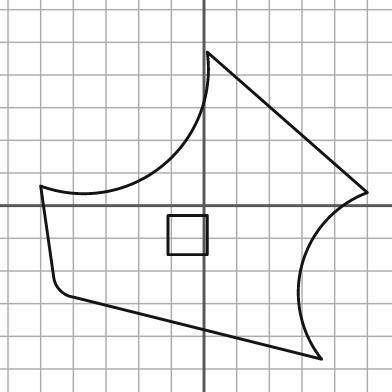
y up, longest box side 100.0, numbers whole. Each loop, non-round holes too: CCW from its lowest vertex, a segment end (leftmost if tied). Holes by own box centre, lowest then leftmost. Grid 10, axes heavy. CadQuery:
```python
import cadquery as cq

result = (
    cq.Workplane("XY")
    .moveTo(36.0, -47.0)
    .threePointArc((30.0, -18.0), (50.0, 4.0))
    .lineTo(1.0, 47.0)
    .threePointArc((-13.0, 12.0), (-50.0, 6.0))
    .lineTo(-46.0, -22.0)
    .threePointArc((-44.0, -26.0), (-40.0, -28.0))
    .close()
    .moveTo(-11.0, -15.0)
    .lineTo(1.0, -15.0)
    .lineTo(1.0, -3.0)
    .lineTo(-11.0, -3.0)
    .close()
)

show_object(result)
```